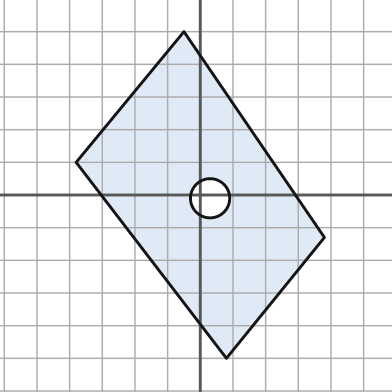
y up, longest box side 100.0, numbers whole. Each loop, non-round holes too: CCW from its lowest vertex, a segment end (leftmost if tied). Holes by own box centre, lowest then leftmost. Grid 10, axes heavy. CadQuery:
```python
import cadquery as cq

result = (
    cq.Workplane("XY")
    .moveTo(8.0, -50.0)
    .lineTo(38.0, -13.0)
    .lineTo(-5.0, 50.0)
    .lineTo(-38.0, 10.0)
    .close()
    .moveTo(3.0, -1.0)
    .circle(6.0)
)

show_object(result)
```